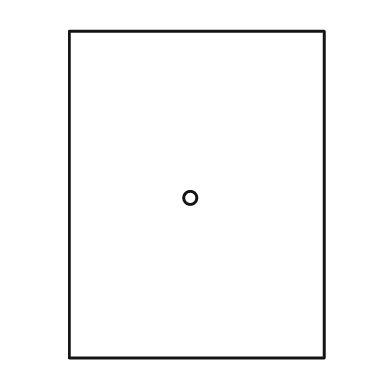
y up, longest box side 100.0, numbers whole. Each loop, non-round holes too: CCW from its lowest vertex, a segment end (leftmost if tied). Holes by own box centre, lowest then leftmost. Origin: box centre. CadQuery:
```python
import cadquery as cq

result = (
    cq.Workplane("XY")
    .moveTo(-39.0, -50.0)
    .lineTo(39.0, -50.0)
    .lineTo(39.0, 50.0)
    .lineTo(-39.0, 50.0)
    .close()
    .moveTo(-2.0, -1.0)
    .circle(2.0)
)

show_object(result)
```